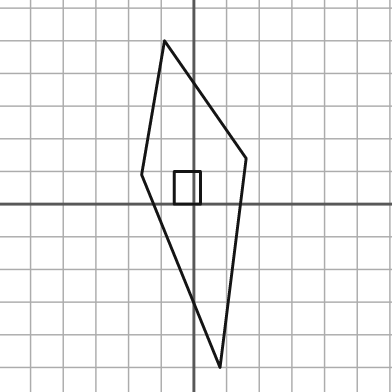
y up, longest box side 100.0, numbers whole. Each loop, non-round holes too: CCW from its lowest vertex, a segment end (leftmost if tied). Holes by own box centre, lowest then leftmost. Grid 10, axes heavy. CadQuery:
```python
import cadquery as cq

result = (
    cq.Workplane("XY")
    .moveTo(8.0, -50.0)
    .lineTo(16.0, 14.0)
    .lineTo(-9.0, 50.0)
    .lineTo(-16.0, 9.0)
    .close()
    .moveTo(-6.0, 0.0)
    .lineTo(2.0, 0.0)
    .lineTo(2.0, 10.0)
    .lineTo(-6.0, 10.0)
    .close()
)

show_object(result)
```